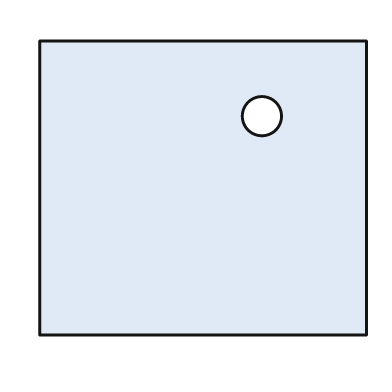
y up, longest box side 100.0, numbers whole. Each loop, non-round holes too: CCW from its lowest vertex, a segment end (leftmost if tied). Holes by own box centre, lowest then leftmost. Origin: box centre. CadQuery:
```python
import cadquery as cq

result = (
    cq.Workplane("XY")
    .moveTo(-50.0, -45.0)
    .lineTo(50.0, -45.0)
    .lineTo(50.0, 45.0)
    .lineTo(-50.0, 45.0)
    .close()
    .moveTo(18.0, 22.0)
    .circle(6.0)
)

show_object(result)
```